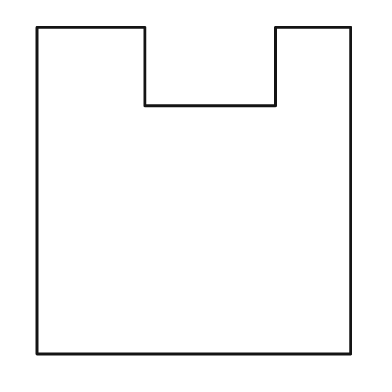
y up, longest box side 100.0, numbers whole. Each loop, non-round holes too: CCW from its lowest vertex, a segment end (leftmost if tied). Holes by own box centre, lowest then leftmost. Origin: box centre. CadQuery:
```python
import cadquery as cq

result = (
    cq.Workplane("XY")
    .moveTo(-48.0, -50.0)
    .lineTo(48.0, -50.0)
    .lineTo(48.0, 50.0)
    .lineTo(25.0, 50.0)
    .lineTo(25.0, 26.0)
    .lineTo(-15.0, 26.0)
    .lineTo(-15.0, 50.0)
    .lineTo(-48.0, 50.0)
    .close()
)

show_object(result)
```